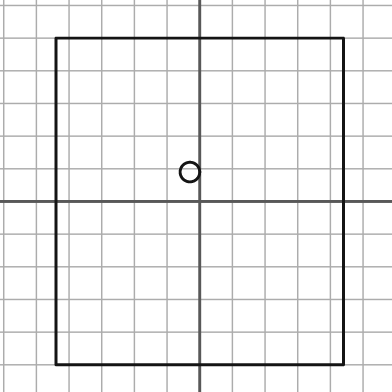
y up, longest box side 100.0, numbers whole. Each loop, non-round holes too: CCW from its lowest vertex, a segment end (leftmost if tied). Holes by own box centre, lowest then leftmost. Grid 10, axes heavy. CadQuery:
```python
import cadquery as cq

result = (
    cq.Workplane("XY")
    .moveTo(-44.0, -50.0)
    .lineTo(44.0, -50.0)
    .lineTo(44.0, 50.0)
    .lineTo(-44.0, 50.0)
    .close()
    .moveTo(-3.0, 9.0)
    .circle(3.0)
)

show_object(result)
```